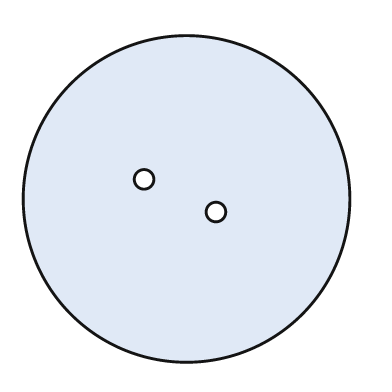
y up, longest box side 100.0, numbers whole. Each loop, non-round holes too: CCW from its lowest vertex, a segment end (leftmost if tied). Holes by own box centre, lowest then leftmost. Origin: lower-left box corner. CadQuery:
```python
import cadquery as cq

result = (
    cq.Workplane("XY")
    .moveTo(50.0, 50.0)
    .circle(50.0)
    .moveTo(59.0, 46.0)
    .circle(3.0)
    .moveTo(37.0, 56.0)
    .circle(3.0)
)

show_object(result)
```